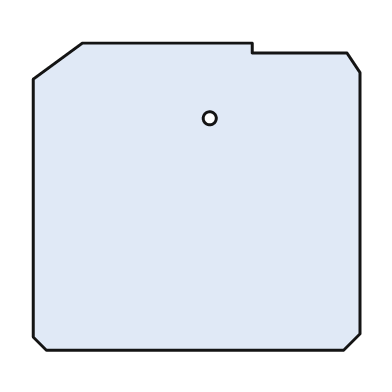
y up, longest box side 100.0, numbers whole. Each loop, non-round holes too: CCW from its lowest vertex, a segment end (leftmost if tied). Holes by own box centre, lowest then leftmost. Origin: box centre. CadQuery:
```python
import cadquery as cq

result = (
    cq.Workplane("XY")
    .moveTo(-46.0, -47.0)
    .lineTo(45.0, -47.0)
    .lineTo(50.0, -42.0)
    .lineTo(50.0, 38.0)
    .lineTo(46.0, 44.0)
    .lineTo(17.0, 44.0)
    .lineTo(17.0, 47.0)
    .lineTo(-35.0, 47.0)
    .lineTo(-50.0, 36.0)
    .lineTo(-50.0, -43.0)
    .close()
    .moveTo(4.0, 24.0)
    .circle(2.0)
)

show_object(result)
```